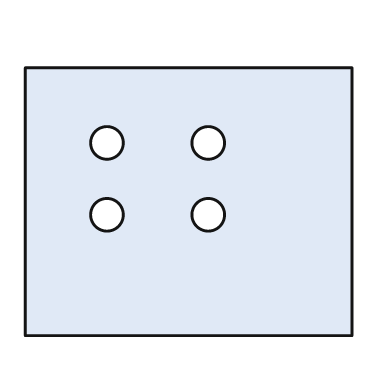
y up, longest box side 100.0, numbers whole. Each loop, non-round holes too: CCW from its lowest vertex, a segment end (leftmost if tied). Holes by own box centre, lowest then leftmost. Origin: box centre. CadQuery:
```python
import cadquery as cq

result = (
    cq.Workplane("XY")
    .moveTo(-50.0, -41.0)
    .lineTo(50.0, -41.0)
    .lineTo(50.0, 41.0)
    .lineTo(-50.0, 41.0)
    .close()
    .moveTo(-25.0, -4.0)
    .circle(5.0)
    .moveTo(6.0, -4.0)
    .circle(5.0)
    .moveTo(-25.0, 18.0)
    .circle(5.0)
    .moveTo(6.0, 18.0)
    .circle(5.0)
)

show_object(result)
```